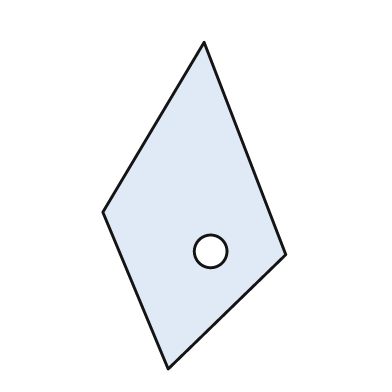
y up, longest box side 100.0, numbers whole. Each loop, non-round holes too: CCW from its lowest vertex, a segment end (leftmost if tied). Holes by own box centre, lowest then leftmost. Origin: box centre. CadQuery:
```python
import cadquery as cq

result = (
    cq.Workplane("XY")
    .moveTo(-8.0, -50.0)
    .lineTo(28.0, -15.0)
    .lineTo(3.0, 50.0)
    .lineTo(-28.0, -2.0)
    .close()
    .moveTo(5.0, -14.0)
    .circle(5.0)
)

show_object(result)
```